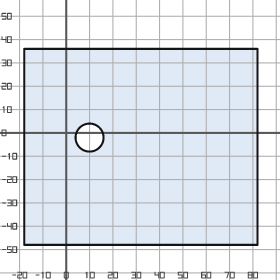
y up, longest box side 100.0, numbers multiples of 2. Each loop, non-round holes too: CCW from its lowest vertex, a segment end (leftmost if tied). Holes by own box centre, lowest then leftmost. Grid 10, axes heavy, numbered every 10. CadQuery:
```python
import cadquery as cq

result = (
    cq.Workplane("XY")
    .moveTo(-18.0, -48.0)
    .lineTo(82.0, -48.0)
    .lineTo(82.0, 36.0)
    .lineTo(-18.0, 36.0)
    .close()
    .moveTo(10.0, -2.0)
    .circle(6.0)
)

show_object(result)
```